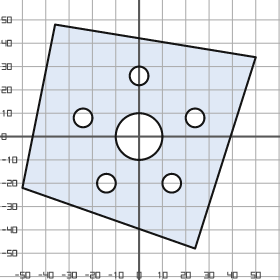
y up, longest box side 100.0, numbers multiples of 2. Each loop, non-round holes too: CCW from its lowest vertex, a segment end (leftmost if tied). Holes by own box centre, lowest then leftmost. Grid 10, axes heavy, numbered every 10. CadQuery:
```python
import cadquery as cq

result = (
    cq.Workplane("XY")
    .moveTo(24.0, -48.0)
    .lineTo(50.0, 34.0)
    .lineTo(-36.0, 48.0)
    .lineTo(-50.0, -22.0)
    .close()
    .moveTo(-14.0, -20.0)
    .circle(4.0)
    .moveTo(14.0, -20.0)
    .circle(4.0)
    .moveTo(0.0, 0.0)
    .circle(10.0)
    .moveTo(-24.0, 8.0)
    .circle(4.0)
    .moveTo(24.0, 8.0)
    .circle(4.0)
    .moveTo(0.0, 26.0)
    .circle(4.0)
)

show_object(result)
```